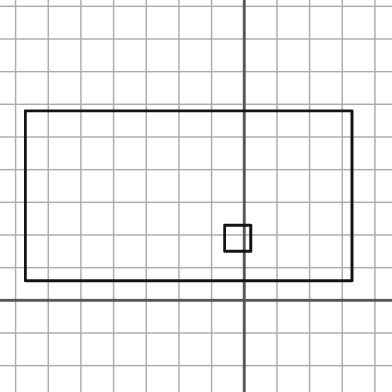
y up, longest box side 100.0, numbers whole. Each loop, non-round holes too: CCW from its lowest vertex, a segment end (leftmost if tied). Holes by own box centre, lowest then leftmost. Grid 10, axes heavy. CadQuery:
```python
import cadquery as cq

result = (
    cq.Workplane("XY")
    .moveTo(-67.0, 6.0)
    .lineTo(33.0, 6.0)
    .lineTo(33.0, 58.0)
    .lineTo(-67.0, 58.0)
    .close()
    .moveTo(-6.0, 15.0)
    .lineTo(2.0, 15.0)
    .lineTo(2.0, 23.0)
    .lineTo(-6.0, 23.0)
    .close()
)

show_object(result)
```